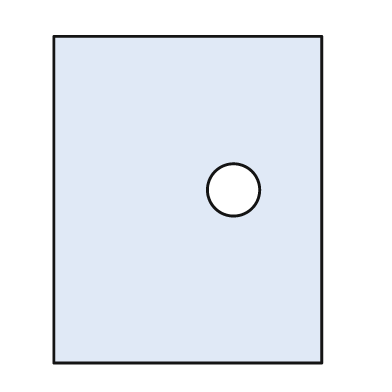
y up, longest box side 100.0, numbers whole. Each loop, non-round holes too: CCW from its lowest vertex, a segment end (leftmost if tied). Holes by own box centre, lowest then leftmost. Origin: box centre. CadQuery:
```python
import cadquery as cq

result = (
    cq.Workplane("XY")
    .moveTo(-41.0, -50.0)
    .lineTo(41.0, -50.0)
    .lineTo(41.0, 50.0)
    .lineTo(-41.0, 50.0)
    .close()
    .moveTo(14.0, 3.0)
    .circle(8.0)
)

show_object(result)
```